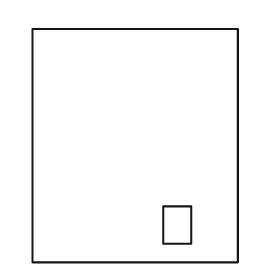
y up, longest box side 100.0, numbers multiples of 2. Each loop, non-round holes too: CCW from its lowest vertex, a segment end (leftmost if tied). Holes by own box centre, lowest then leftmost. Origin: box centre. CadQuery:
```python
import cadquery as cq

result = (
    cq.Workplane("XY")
    .moveTo(-44.0, -50.0)
    .lineTo(44.0, -50.0)
    .lineTo(44.0, 50.0)
    .lineTo(-44.0, 50.0)
    .close()
    .moveTo(12.0, -42.0)
    .lineTo(24.0, -42.0)
    .lineTo(24.0, -26.0)
    .lineTo(12.0, -26.0)
    .close()
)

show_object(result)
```